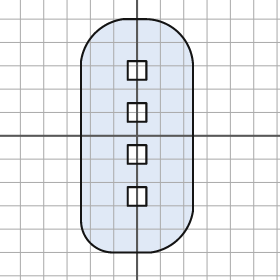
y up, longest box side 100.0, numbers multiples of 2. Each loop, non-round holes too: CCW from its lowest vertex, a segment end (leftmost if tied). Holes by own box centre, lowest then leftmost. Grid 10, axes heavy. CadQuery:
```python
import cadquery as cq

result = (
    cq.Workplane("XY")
    .moveTo(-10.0, -50.0)
    .lineTo(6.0, -50.0)
    .threePointArc((18.0, -44.0), (24.0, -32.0))
    .lineTo(24.0, 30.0)
    .threePointArc((18.0, 44.0), (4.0, 50.0))
    .lineTo(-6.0, 50.0)
    .threePointArc((-18.0, 44.0), (-24.0, 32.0))
    .lineTo(-24.0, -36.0)
    .threePointArc((-20.0, -46.0), (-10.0, -50.0))
    .close()
    .moveTo(-4.0, -30.0)
    .lineTo(4.0, -30.0)
    .lineTo(4.0, -22.0)
    .lineTo(-4.0, -22.0)
    .close()
    .moveTo(-4.0, -12.0)
    .lineTo(4.0, -12.0)
    .lineTo(4.0, -4.0)
    .lineTo(-4.0, -4.0)
    .close()
    .moveTo(-4.0, 6.0)
    .lineTo(4.0, 6.0)
    .lineTo(4.0, 14.0)
    .lineTo(-4.0, 14.0)
    .close()
    .moveTo(-4.0, 24.0)
    .lineTo(4.0, 24.0)
    .lineTo(4.0, 32.0)
    .lineTo(-4.0, 32.0)
    .close()
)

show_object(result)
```